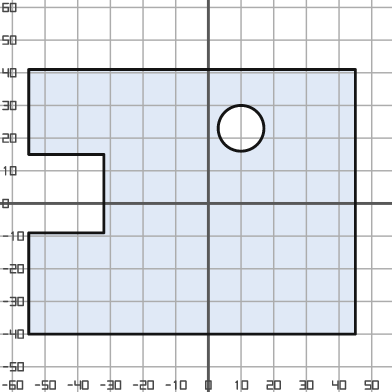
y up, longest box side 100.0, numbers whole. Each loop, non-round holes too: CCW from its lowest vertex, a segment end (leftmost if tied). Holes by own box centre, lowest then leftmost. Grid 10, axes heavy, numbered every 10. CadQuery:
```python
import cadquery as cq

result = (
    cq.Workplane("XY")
    .moveTo(-55.0, -40.0)
    .lineTo(45.0, -40.0)
    .lineTo(45.0, 41.0)
    .lineTo(-55.0, 41.0)
    .lineTo(-55.0, 15.0)
    .lineTo(-32.0, 15.0)
    .lineTo(-32.0, -9.0)
    .lineTo(-55.0, -9.0)
    .close()
    .moveTo(10.0, 23.0)
    .circle(7.0)
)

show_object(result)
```